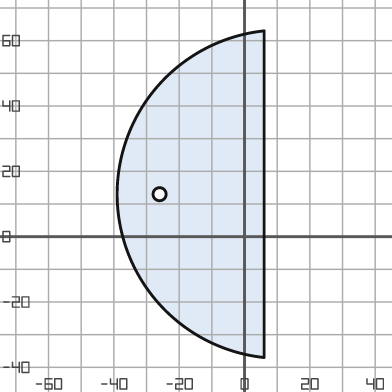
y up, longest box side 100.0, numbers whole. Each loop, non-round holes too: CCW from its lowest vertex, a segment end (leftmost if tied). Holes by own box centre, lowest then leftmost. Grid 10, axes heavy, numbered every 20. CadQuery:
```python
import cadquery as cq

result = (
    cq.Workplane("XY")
    .moveTo(6.0, -37.0)
    .lineTo(6.0, 63.0)
    .threePointArc((-39.0, 13.0), (6.0, -37.0))
    .close()
    .moveTo(-26.0, 13.0)
    .circle(2.0)
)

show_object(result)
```